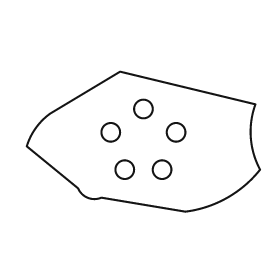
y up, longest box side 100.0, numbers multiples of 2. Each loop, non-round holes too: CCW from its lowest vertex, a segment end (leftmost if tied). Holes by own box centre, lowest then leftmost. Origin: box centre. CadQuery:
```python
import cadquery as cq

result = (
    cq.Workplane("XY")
    .moveTo(18.0, -30.0)
    .threePointArc((36.0, -24.0), (50.0, -12.0))
    .threePointArc((46.0, 2.0), (48.0, 16.0))
    .lineTo(-10.0, 30.0)
    .lineTo(-40.0, 12.0)
    .threePointArc((-46.0, 6.0), (-50.0, -2.0))
    .lineTo(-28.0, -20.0)
    .threePointArc((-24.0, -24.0), (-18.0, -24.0))
    .close()
    .moveTo(-8.0, -12.0)
    .circle(4.0)
    .moveTo(8.0, -12.0)
    .circle(4.0)
    .moveTo(-14.0, 4.0)
    .circle(4.0)
    .moveTo(14.0, 4.0)
    .circle(4.0)
    .moveTo(0.0, 14.0)
    .circle(4.0)
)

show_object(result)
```